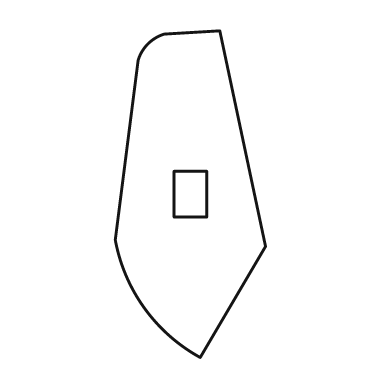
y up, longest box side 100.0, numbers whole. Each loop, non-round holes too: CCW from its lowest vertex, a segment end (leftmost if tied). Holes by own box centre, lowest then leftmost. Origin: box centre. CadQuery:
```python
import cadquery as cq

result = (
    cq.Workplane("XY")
    .moveTo(3.0, -50.0)
    .lineTo(23.0, -16.0)
    .lineTo(9.0, 50.0)
    .lineTo(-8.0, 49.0)
    .threePointArc((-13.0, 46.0), (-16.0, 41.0))
    .lineTo(-23.0, -14.0)
    .threePointArc((-14.0, -35.0), (3.0, -50.0))
    .close()
    .moveTo(-5.0, -7.0)
    .lineTo(5.0, -7.0)
    .lineTo(5.0, 7.0)
    .lineTo(-5.0, 7.0)
    .close()
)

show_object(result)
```